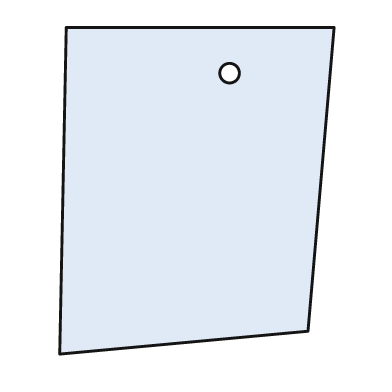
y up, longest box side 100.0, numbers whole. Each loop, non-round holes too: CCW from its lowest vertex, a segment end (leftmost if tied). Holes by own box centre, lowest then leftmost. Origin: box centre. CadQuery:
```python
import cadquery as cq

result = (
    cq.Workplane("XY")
    .moveTo(-42.0, -50.0)
    .lineTo(34.0, -43.0)
    .lineTo(42.0, 50.0)
    .lineTo(-40.0, 50.0)
    .close()
    .moveTo(10.0, 36.0)
    .circle(3.0)
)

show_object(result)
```